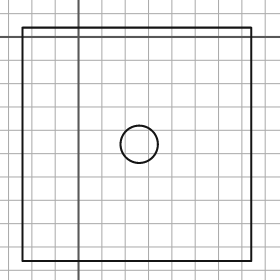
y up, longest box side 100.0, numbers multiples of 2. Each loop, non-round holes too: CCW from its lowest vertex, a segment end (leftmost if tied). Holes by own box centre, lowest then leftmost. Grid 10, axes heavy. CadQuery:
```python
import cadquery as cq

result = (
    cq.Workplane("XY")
    .moveTo(-24.0, -96.0)
    .lineTo(74.0, -96.0)
    .lineTo(74.0, 4.0)
    .lineTo(-24.0, 4.0)
    .close()
    .moveTo(26.0, -46.0)
    .circle(8.0)
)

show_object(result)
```